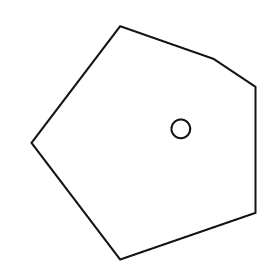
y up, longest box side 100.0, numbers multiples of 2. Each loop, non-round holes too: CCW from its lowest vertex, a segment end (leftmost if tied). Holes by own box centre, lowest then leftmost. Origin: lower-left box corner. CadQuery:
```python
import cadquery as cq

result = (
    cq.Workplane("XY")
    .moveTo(38.0, 0.0)
    .lineTo(96.0, 20.0)
    .lineTo(96.0, 74.0)
    .lineTo(78.0, 86.0)
    .lineTo(38.0, 100.0)
    .lineTo(0.0, 50.0)
    .close()
    .moveTo(64.0, 56.0)
    .circle(4.0)
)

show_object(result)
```